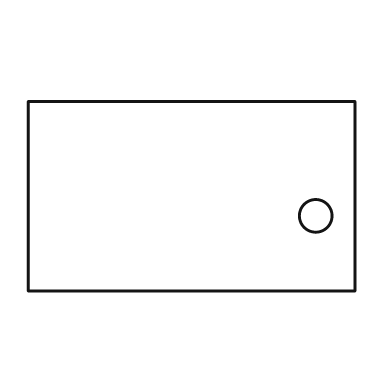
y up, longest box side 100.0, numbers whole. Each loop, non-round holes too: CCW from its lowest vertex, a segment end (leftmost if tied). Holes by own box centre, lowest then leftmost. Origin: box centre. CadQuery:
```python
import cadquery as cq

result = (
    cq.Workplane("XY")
    .moveTo(-50.0, -29.0)
    .lineTo(50.0, -29.0)
    .lineTo(50.0, 29.0)
    .lineTo(-50.0, 29.0)
    .close()
    .moveTo(38.0, -6.0)
    .circle(5.0)
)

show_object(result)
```